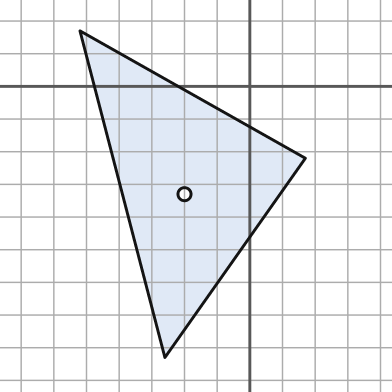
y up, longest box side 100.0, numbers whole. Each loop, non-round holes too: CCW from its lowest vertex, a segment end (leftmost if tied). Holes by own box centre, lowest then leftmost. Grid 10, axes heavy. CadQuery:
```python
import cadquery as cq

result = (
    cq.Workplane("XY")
    .moveTo(-26.0, -83.0)
    .lineTo(17.0, -22.0)
    .lineTo(-52.0, 17.0)
    .close()
    .moveTo(-20.0, -33.0)
    .circle(2.0)
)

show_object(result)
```